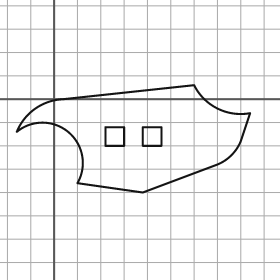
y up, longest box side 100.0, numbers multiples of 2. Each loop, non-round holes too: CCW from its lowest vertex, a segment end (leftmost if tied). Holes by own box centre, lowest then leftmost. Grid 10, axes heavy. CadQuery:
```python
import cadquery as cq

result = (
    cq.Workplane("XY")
    .moveTo(38.0, -40.0)
    .lineTo(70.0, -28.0)
    .threePointArc((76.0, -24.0), (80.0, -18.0))
    .lineTo(84.0, -6.0)
    .threePointArc((70.0, -4.0), (60.0, 6.0))
    .lineTo(4.0, 0.0)
    .threePointArc((-8.0, -4.0), (-16.0, -14.0))
    .threePointArc((6.0, -14.0), (10.0, -36.0))
    .close()
    .moveTo(22.0, -20.0)
    .lineTo(30.0, -20.0)
    .lineTo(30.0, -12.0)
    .lineTo(22.0, -12.0)
    .close()
    .moveTo(38.0, -20.0)
    .lineTo(46.0, -20.0)
    .lineTo(46.0, -12.0)
    .lineTo(38.0, -12.0)
    .close()
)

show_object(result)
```